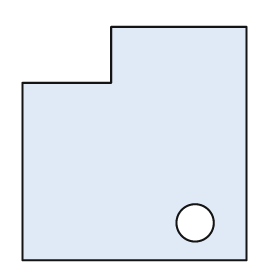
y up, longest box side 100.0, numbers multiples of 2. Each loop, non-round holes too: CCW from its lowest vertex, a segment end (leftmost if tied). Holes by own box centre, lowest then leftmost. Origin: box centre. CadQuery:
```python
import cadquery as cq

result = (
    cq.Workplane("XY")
    .moveTo(-48.0, -50.0)
    .lineTo(48.0, -50.0)
    .lineTo(48.0, 50.0)
    .lineTo(-10.0, 50.0)
    .lineTo(-10.0, 26.0)
    .lineTo(-48.0, 26.0)
    .close()
    .moveTo(26.0, -34.0)
    .circle(8.0)
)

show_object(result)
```